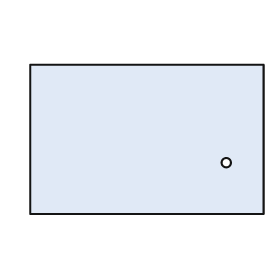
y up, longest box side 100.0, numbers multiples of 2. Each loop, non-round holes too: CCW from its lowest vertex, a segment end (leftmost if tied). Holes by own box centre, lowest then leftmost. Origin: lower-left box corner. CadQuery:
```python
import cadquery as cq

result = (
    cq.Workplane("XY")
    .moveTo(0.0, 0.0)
    .lineTo(100.0, 0.0)
    .lineTo(100.0, 64.0)
    .lineTo(0.0, 64.0)
    .close()
    .moveTo(84.0, 22.0)
    .circle(2.0)
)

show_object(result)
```